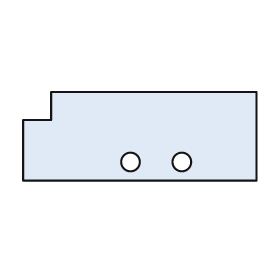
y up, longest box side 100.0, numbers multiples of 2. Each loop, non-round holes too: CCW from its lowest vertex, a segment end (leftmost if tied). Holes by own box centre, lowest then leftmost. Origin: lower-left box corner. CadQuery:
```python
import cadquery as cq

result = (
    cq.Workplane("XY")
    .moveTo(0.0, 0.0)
    .lineTo(100.0, 0.0)
    .lineTo(100.0, 38.0)
    .lineTo(12.0, 38.0)
    .lineTo(12.0, 26.0)
    .lineTo(0.0, 26.0)
    .close()
    .moveTo(46.0, 8.0)
    .circle(4.0)
    .moveTo(68.0, 8.0)
    .circle(4.0)
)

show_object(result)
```